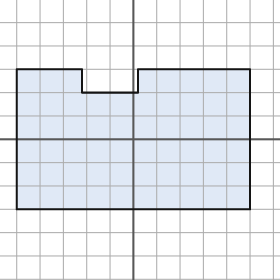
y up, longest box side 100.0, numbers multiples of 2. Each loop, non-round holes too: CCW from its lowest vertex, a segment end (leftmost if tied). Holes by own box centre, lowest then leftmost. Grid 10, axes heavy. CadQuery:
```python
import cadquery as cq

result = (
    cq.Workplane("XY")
    .moveTo(-50.0, -30.0)
    .lineTo(50.0, -30.0)
    .lineTo(50.0, 30.0)
    .lineTo(2.0, 30.0)
    .lineTo(2.0, 20.0)
    .lineTo(-22.0, 20.0)
    .lineTo(-22.0, 30.0)
    .lineTo(-50.0, 30.0)
    .close()
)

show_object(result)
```